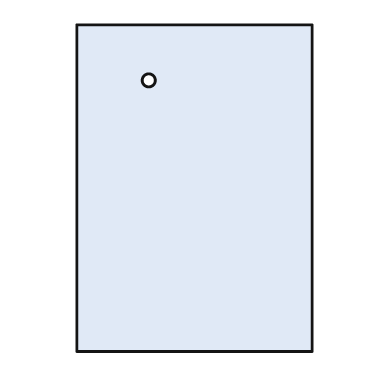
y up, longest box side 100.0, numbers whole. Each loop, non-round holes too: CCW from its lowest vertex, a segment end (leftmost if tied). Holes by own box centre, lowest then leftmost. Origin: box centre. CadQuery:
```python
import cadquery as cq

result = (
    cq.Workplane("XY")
    .moveTo(-36.0, -50.0)
    .lineTo(36.0, -50.0)
    .lineTo(36.0, 50.0)
    .lineTo(-36.0, 50.0)
    .close()
    .moveTo(-14.0, 33.0)
    .circle(2.0)
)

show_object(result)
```